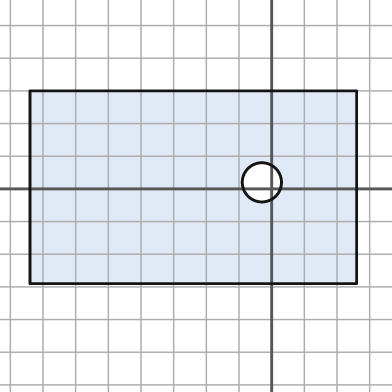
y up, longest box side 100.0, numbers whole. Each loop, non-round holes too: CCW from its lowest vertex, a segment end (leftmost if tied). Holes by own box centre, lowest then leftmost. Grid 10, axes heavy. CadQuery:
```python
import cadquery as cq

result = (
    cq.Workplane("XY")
    .moveTo(-74.0, -29.0)
    .lineTo(26.0, -29.0)
    .lineTo(26.0, 30.0)
    .lineTo(-74.0, 30.0)
    .close()
    .moveTo(-3.0, 2.0)
    .circle(6.0)
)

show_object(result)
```